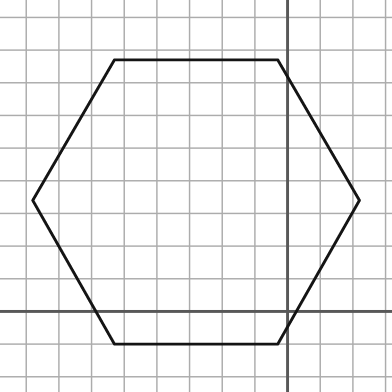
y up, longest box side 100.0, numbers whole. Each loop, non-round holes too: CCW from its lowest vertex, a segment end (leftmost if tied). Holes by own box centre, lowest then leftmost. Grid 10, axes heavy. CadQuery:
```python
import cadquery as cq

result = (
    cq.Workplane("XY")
    .moveTo(-53.0, -10.0)
    .lineTo(-3.0, -10.0)
    .lineTo(22.0, 34.0)
    .lineTo(-3.0, 77.0)
    .lineTo(-53.0, 77.0)
    .lineTo(-78.0, 34.0)
    .close()
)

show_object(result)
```